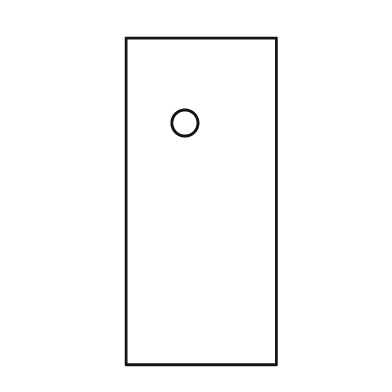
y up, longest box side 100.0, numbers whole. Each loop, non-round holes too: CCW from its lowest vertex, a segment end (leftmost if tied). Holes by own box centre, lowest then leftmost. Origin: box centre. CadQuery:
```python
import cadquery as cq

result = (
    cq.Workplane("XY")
    .moveTo(-23.0, -50.0)
    .lineTo(23.0, -50.0)
    .lineTo(23.0, 50.0)
    .lineTo(-23.0, 50.0)
    .close()
    .moveTo(-5.0, 24.0)
    .circle(4.0)
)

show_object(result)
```